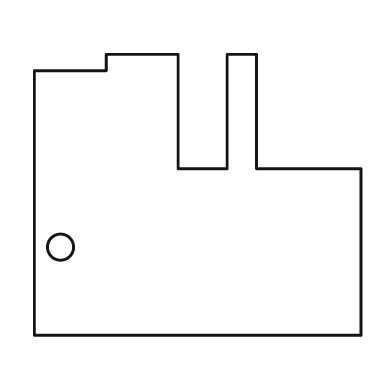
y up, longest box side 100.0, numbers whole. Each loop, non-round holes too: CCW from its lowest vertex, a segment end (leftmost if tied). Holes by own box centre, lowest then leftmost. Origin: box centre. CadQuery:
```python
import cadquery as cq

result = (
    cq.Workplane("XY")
    .moveTo(-50.0, -43.0)
    .lineTo(50.0, -43.0)
    .lineTo(50.0, 8.0)
    .lineTo(18.0, 8.0)
    .lineTo(18.0, 43.0)
    .lineTo(9.0, 43.0)
    .lineTo(9.0, 8.0)
    .lineTo(-6.0, 8.0)
    .lineTo(-6.0, 43.0)
    .lineTo(-28.0, 43.0)
    .lineTo(-28.0, 38.0)
    .lineTo(-50.0, 38.0)
    .close()
    .moveTo(-42.0, -16.0)
    .circle(4.0)
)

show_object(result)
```